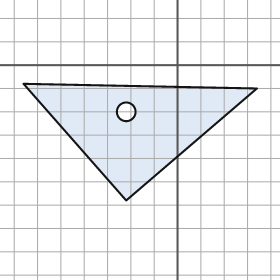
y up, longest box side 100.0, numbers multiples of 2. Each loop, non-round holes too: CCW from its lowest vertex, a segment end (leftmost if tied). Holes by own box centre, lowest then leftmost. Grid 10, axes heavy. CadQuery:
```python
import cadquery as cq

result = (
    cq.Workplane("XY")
    .moveTo(-22.0, -58.0)
    .lineTo(34.0, -10.0)
    .lineTo(-66.0, -8.0)
    .close()
    .moveTo(-22.0, -20.0)
    .circle(4.0)
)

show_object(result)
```